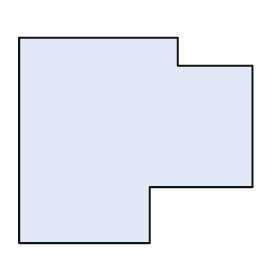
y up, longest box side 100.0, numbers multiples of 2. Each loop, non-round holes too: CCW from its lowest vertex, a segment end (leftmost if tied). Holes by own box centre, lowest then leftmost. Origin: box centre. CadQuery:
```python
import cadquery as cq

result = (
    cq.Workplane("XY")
    .moveTo(-50.0, -44.0)
    .lineTo(6.0, -44.0)
    .lineTo(6.0, -20.0)
    .lineTo(50.0, -20.0)
    .lineTo(50.0, 32.0)
    .lineTo(18.0, 32.0)
    .lineTo(18.0, 44.0)
    .lineTo(-50.0, 44.0)
    .close()
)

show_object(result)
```